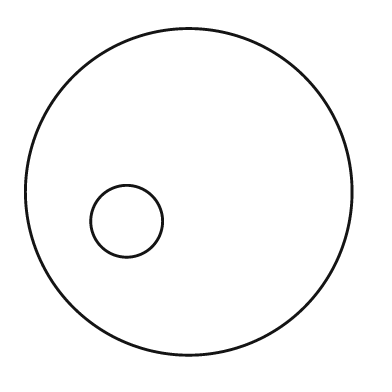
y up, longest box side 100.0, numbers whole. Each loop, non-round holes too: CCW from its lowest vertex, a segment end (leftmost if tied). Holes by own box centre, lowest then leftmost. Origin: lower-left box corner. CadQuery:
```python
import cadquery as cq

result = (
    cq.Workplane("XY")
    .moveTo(50.0, 50.0)
    .circle(50.0)
    .moveTo(31.0, 41.0)
    .circle(11.0)
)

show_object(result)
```